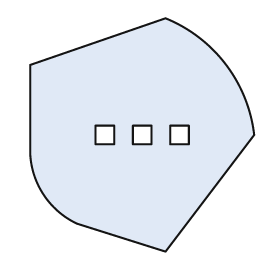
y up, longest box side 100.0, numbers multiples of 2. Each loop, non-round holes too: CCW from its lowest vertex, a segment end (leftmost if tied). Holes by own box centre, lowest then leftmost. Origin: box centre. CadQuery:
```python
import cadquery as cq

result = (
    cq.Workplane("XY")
    .moveTo(10.0, -50.0)
    .lineTo(48.0, 0.0)
    .threePointArc((36.0, 30.0), (10.0, 50.0))
    .lineTo(-48.0, 30.0)
    .lineTo(-48.0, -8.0)
    .threePointArc((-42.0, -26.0), (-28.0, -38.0))
    .close()
    .moveTo(-20.0, -4.0)
    .lineTo(-12.0, -4.0)
    .lineTo(-12.0, 4.0)
    .lineTo(-20.0, 4.0)
    .close()
    .moveTo(-4.0, -4.0)
    .lineTo(4.0, -4.0)
    .lineTo(4.0, 4.0)
    .lineTo(-4.0, 4.0)
    .close()
    .moveTo(12.0, -4.0)
    .lineTo(20.0, -4.0)
    .lineTo(20.0, 4.0)
    .lineTo(12.0, 4.0)
    .close()
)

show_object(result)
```